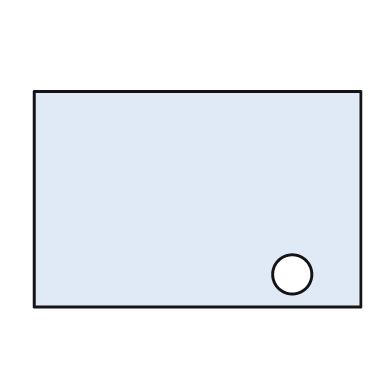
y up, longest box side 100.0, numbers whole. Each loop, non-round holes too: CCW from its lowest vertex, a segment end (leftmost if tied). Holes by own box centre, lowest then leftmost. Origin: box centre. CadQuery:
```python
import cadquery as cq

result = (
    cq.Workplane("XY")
    .moveTo(-50.0, -33.0)
    .lineTo(50.0, -33.0)
    .lineTo(50.0, 33.0)
    .lineTo(-50.0, 33.0)
    .close()
    .moveTo(29.0, -23.0)
    .circle(6.0)
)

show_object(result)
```